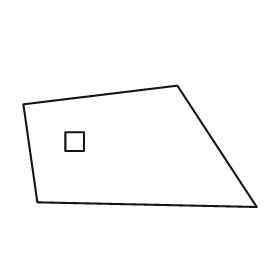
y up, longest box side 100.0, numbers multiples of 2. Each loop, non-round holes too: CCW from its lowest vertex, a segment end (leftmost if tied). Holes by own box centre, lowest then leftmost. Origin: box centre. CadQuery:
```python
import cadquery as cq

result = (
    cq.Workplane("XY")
    .moveTo(50.0, -26.0)
    .lineTo(16.0, 26.0)
    .lineTo(-50.0, 18.0)
    .lineTo(-44.0, -24.0)
    .close()
    .moveTo(-32.0, -2.0)
    .lineTo(-24.0, -2.0)
    .lineTo(-24.0, 6.0)
    .lineTo(-32.0, 6.0)
    .close()
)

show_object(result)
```